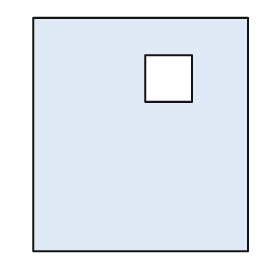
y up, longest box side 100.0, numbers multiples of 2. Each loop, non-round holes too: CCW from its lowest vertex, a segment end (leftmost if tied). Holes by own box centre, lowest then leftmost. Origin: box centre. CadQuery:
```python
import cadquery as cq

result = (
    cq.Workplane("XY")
    .moveTo(-46.0, -50.0)
    .lineTo(46.0, -50.0)
    .lineTo(46.0, 50.0)
    .lineTo(-46.0, 50.0)
    .close()
    .moveTo(2.0, 14.0)
    .lineTo(22.0, 14.0)
    .lineTo(22.0, 34.0)
    .lineTo(2.0, 34.0)
    .close()
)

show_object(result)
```